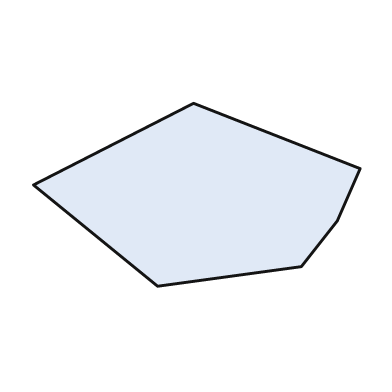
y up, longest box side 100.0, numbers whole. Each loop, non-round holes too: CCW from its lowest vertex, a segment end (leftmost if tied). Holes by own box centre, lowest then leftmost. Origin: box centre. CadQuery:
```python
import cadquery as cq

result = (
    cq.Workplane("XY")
    .moveTo(-12.0, -28.0)
    .lineTo(32.0, -22.0)
    .lineTo(43.0, -8.0)
    .lineTo(50.0, 8.0)
    .lineTo(-1.0, 28.0)
    .lineTo(-50.0, 3.0)
    .close()
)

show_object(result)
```